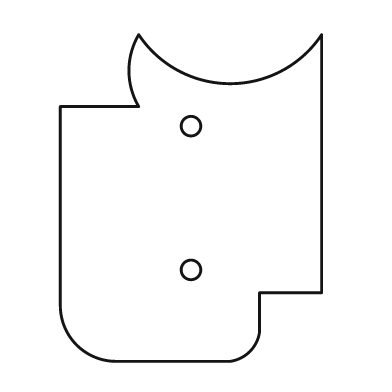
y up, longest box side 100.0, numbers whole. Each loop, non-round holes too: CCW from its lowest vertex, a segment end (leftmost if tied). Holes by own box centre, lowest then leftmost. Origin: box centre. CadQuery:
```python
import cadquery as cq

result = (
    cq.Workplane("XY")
    .moveTo(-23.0, -50.0)
    .lineTo(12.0, -50.0)
    .threePointArc((18.0, -47.0), (21.0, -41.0))
    .lineTo(21.0, -29.0)
    .lineTo(40.0, -29.0)
    .lineTo(40.0, 50.0)
    .threePointArc((12.0, 35.0), (-16.0, 50.0))
    .threePointArc((-19.0, 39.0), (-16.0, 28.0))
    .lineTo(-40.0, 28.0)
    .lineTo(-40.0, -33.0)
    .threePointArc((-35.0, -45.0), (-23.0, -50.0))
    .close()
    .moveTo(0.0, -22.0)
    .circle(3.0)
    .moveTo(0.0, 22.0)
    .circle(3.0)
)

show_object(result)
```